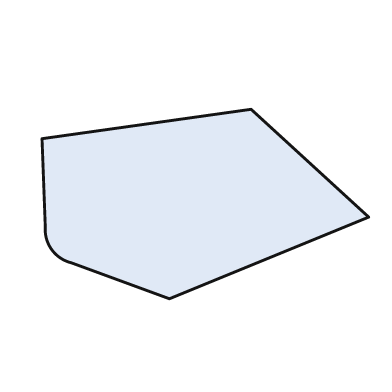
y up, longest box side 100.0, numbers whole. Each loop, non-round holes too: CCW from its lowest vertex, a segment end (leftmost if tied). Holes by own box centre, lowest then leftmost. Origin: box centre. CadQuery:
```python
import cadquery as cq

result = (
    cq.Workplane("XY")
    .moveTo(-11.0, -29.0)
    .lineTo(50.0, -4.0)
    .lineTo(14.0, 29.0)
    .lineTo(-50.0, 20.0)
    .lineTo(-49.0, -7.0)
    .threePointArc((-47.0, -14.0), (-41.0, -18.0))
    .close()
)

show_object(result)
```